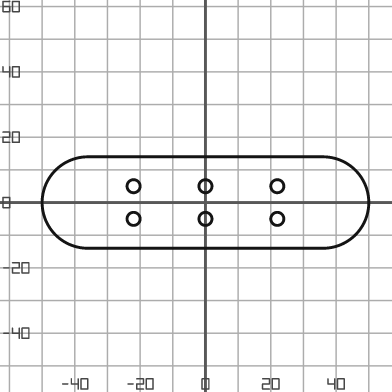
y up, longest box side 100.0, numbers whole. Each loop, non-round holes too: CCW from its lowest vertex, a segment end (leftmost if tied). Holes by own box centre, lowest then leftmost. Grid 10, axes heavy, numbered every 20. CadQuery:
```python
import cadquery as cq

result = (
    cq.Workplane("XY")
    .moveTo(-36.0, -14.0)
    .lineTo(36.0, -14.0)
    .threePointArc((50.0, 0.0), (36.0, 14.0))
    .lineTo(-36.0, 14.0)
    .threePointArc((-50.0, 0.0), (-36.0, -14.0))
    .close()
    .moveTo(-22.0, -5.0)
    .circle(2.0)
    .moveTo(0.0, -5.0)
    .circle(2.0)
    .moveTo(22.0, -5.0)
    .circle(2.0)
    .moveTo(-22.0, 5.0)
    .circle(2.0)
    .moveTo(0.0, 5.0)
    .circle(2.0)
    .moveTo(22.0, 5.0)
    .circle(2.0)
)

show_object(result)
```